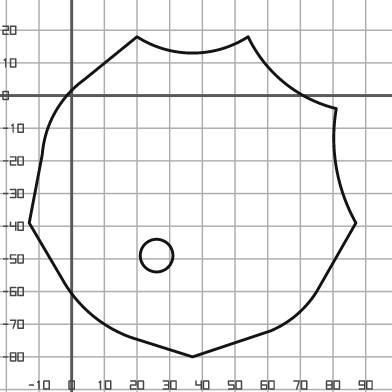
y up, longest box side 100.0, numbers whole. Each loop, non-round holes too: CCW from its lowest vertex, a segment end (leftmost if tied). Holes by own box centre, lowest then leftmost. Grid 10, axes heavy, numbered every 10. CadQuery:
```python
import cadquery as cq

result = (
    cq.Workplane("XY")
    .moveTo(37.0, -80.0)
    .lineTo(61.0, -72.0)
    .threePointArc((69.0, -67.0), (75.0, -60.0))
    .lineTo(87.0, -39.0)
    .threePointArc((81.0, -22.0), (81.0, -4.0))
    .threePointArc((65.0, 4.0), (54.0, 18.0))
    .threePointArc((37.0, 13.0), (20.0, 18.0))
    .lineTo(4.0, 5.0)
    .threePointArc((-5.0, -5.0), (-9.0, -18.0))
    .lineTo(-13.0, -39.0)
    .lineTo(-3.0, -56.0)
    .threePointArc((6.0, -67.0), (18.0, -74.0))
    .close()
    .moveTo(26.0, -49.0)
    .circle(5.0)
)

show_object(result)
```